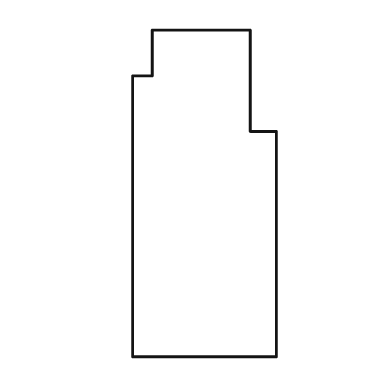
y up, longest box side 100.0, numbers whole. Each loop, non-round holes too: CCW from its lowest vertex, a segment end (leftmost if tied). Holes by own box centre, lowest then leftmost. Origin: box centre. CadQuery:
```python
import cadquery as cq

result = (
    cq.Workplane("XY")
    .moveTo(-22.0, -50.0)
    .lineTo(22.0, -50.0)
    .lineTo(22.0, 19.0)
    .lineTo(14.0, 19.0)
    .lineTo(14.0, 50.0)
    .lineTo(-16.0, 50.0)
    .lineTo(-16.0, 36.0)
    .lineTo(-22.0, 36.0)
    .close()
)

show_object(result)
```